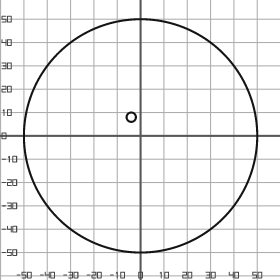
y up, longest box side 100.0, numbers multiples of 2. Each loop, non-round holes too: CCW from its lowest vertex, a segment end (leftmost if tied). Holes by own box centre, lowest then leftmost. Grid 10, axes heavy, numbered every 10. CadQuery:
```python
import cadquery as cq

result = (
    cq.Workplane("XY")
    .moveTo(0.0, 0.0)
    .circle(50.0)
    .moveTo(-4.0, 8.0)
    .circle(2.0)
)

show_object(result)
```